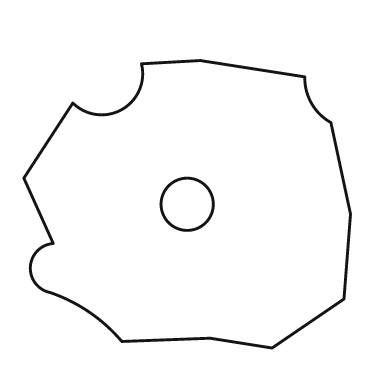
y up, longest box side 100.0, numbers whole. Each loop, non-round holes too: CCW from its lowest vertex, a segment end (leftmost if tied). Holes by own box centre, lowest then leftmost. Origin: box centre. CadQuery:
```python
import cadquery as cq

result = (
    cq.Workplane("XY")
    .moveTo(26.0, -44.0)
    .lineTo(48.0, -29.0)
    .lineTo(50.0, -3.0)
    .lineTo(44.0, 25.0)
    .threePointArc((38.0, 31.0), (36.0, 39.0))
    .lineTo(4.0, 44.0)
    .lineTo(-14.0, 43.0)
    .threePointArc((-20.0, 29.0), (-35.0, 31.0))
    .lineTo(-50.0, 8.0)
    .lineTo(-41.0, -12.0)
    .threePointArc((-48.0, -19.0), (-42.0, -27.0))
    .threePointArc((-30.0, -33.0), (-20.0, -42.0))
    .lineTo(7.0, -41.0)
    .close()
    .moveTo(0.0, 0.0)
    .circle(8.0)
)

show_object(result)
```